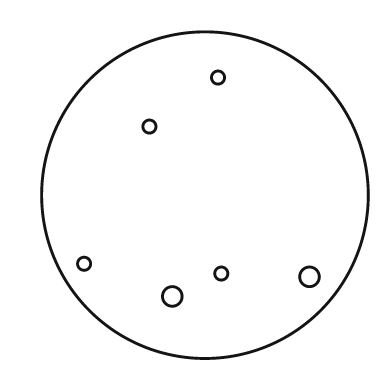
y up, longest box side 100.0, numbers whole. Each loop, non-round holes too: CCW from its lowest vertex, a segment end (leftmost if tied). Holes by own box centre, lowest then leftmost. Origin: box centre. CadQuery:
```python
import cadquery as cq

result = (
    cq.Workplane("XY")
    .moveTo(0.0, 0.0)
    .circle(50.0)
    .moveTo(-10.0, -31.0)
    .circle(3.0)
    .moveTo(32.0, -25.0)
    .circle(3.0)
    .moveTo(5.0, -24.0)
    .circle(2.0)
    .moveTo(-37.0, -21.0)
    .circle(2.0)
    .moveTo(-17.0, 21.0)
    .circle(2.0)
    .moveTo(4.0, 36.0)
    .circle(2.0)
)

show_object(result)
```